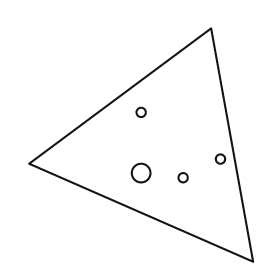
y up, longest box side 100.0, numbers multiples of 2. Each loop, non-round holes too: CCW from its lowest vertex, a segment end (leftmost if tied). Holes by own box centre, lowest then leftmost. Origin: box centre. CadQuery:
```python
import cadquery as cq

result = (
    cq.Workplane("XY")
    .moveTo(48.0, -50.0)
    .lineTo(30.0, 50.0)
    .lineTo(-48.0, -8.0)
    .close()
    .moveTo(18.0, -14.0)
    .circle(2.0)
    .moveTo(0.0, -12.0)
    .circle(4.0)
    .moveTo(34.0, -6.0)
    .circle(2.0)
    .moveTo(0.0, 14.0)
    .circle(2.0)
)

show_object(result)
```